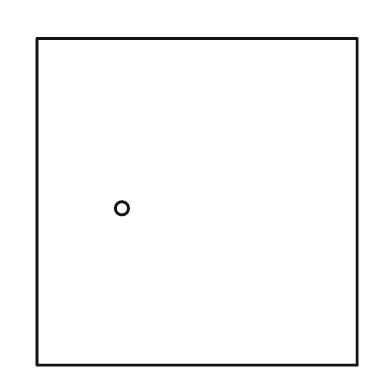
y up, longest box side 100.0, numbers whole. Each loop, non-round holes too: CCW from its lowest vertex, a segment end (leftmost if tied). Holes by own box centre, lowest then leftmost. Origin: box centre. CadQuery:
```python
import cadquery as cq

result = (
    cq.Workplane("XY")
    .moveTo(-49.0, -50.0)
    .lineTo(49.0, -50.0)
    .lineTo(49.0, 50.0)
    .lineTo(-49.0, 50.0)
    .close()
    .moveTo(-23.0, -2.0)
    .circle(2.0)
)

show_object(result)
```